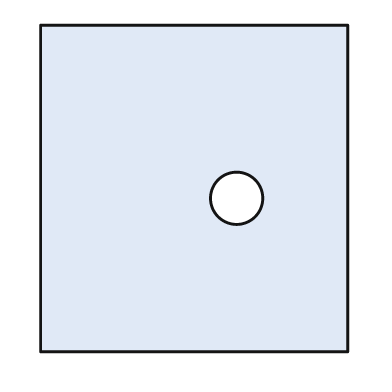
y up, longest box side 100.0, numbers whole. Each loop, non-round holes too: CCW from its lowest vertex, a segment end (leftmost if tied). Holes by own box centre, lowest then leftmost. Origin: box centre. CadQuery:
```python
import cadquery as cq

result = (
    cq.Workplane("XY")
    .moveTo(-47.0, -50.0)
    .lineTo(47.0, -50.0)
    .lineTo(47.0, 50.0)
    .lineTo(-47.0, 50.0)
    .close()
    .moveTo(13.0, -3.0)
    .circle(8.0)
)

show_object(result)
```